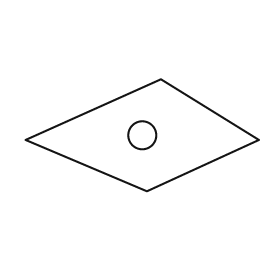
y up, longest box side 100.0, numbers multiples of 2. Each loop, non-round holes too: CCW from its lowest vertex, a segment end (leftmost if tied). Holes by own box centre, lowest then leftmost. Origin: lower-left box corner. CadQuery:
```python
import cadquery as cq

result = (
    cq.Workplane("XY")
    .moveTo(52.0, 0.0)
    .lineTo(100.0, 22.0)
    .lineTo(58.0, 48.0)
    .lineTo(0.0, 22.0)
    .close()
    .moveTo(50.0, 24.0)
    .circle(6.0)
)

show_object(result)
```